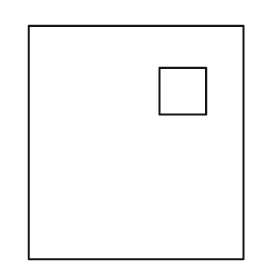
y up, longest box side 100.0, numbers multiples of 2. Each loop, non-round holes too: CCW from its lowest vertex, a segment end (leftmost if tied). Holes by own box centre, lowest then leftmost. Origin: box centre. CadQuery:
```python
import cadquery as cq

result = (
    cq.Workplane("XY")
    .moveTo(-46.0, -50.0)
    .lineTo(46.0, -50.0)
    .lineTo(46.0, 50.0)
    .lineTo(-46.0, 50.0)
    .close()
    .moveTo(10.0, 12.0)
    .lineTo(30.0, 12.0)
    .lineTo(30.0, 32.0)
    .lineTo(10.0, 32.0)
    .close()
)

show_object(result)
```